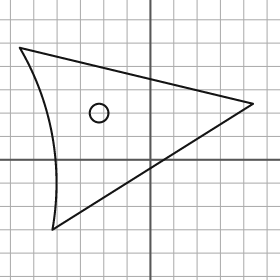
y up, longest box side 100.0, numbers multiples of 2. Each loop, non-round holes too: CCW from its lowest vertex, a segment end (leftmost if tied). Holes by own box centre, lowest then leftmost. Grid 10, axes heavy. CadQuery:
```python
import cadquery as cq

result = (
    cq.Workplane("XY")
    .moveTo(-42.0, -30.0)
    .lineTo(44.0, 24.0)
    .lineTo(-56.0, 48.0)
    .threePointArc((-42.0, 10.0), (-42.0, -30.0))
    .close()
    .moveTo(-22.0, 20.0)
    .circle(4.0)
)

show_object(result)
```